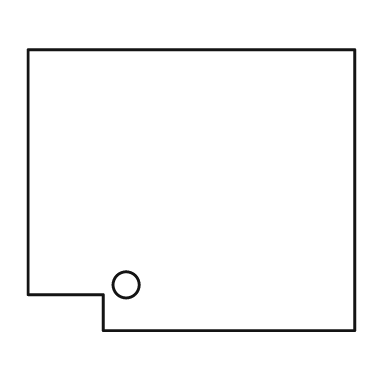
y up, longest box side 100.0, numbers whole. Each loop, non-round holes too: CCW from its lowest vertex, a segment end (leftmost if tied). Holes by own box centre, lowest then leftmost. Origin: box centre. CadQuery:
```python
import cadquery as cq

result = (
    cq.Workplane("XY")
    .moveTo(-27.0, -43.0)
    .lineTo(50.0, -43.0)
    .lineTo(50.0, 43.0)
    .lineTo(-50.0, 43.0)
    .lineTo(-50.0, -32.0)
    .lineTo(-27.0, -32.0)
    .close()
    .moveTo(-20.0, -29.0)
    .circle(4.0)
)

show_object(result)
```